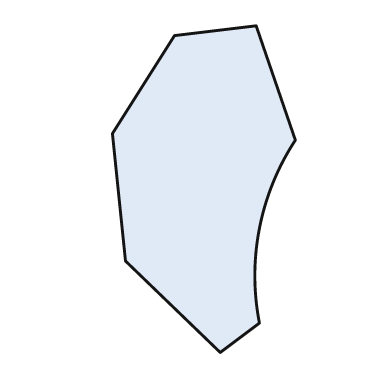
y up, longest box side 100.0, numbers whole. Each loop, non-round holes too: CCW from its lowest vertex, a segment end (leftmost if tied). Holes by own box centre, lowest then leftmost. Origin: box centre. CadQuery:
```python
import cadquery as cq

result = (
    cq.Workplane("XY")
    .moveTo(5.0, -50.0)
    .lineTo(17.0, -41.0)
    .threePointArc((17.0, -12.0), (28.0, 15.0))
    .lineTo(16.0, 50.0)
    .lineTo(-9.0, 47.0)
    .lineTo(-28.0, 17.0)
    .lineTo(-24.0, -22.0)
    .close()
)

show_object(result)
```